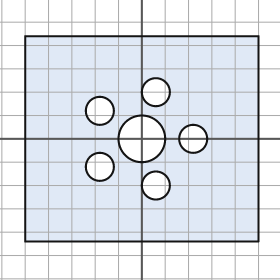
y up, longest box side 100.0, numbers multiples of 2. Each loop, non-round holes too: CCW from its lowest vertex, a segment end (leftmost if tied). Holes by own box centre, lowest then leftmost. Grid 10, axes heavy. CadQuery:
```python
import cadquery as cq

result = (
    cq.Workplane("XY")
    .moveTo(-50.0, -44.0)
    .lineTo(50.0, -44.0)
    .lineTo(50.0, 44.0)
    .lineTo(-50.0, 44.0)
    .close()
    .moveTo(6.0, -20.0)
    .circle(6.0)
    .moveTo(-18.0, -12.0)
    .circle(6.0)
    .moveTo(0.0, 0.0)
    .circle(10.0)
    .moveTo(22.0, 0.0)
    .circle(6.0)
    .moveTo(-18.0, 12.0)
    .circle(6.0)
    .moveTo(6.0, 20.0)
    .circle(6.0)
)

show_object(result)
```